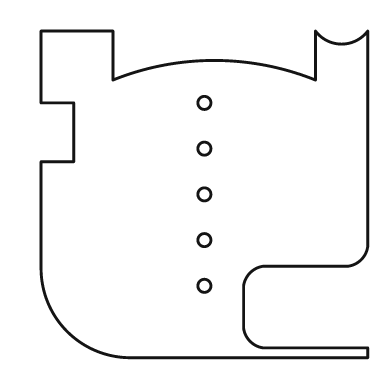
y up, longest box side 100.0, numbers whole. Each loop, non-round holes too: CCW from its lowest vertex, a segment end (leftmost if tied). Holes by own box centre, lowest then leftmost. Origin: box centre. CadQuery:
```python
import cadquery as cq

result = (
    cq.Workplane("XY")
    .moveTo(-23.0, -50.0)
    .lineTo(50.0, -50.0)
    .lineTo(50.0, -47.0)
    .lineTo(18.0, -47.0)
    .threePointArc((14.0, -45.0), (12.0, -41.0))
    .lineTo(12.0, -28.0)
    .threePointArc((14.0, -24.0), (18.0, -22.0))
    .lineTo(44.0, -22.0)
    .threePointArc((48.0, -20.0), (50.0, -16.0))
    .lineTo(50.0, 50.0)
    .threePointArc((42.0, 46.0), (34.0, 50.0))
    .lineTo(34.0, 35.0)
    .threePointArc((3.0, 41.0), (-28.0, 35.0))
    .lineTo(-28.0, 50.0)
    .lineTo(-50.0, 50.0)
    .lineTo(-50.0, 28.0)
    .lineTo(-40.0, 28.0)
    .lineTo(-40.0, 10.0)
    .lineTo(-50.0, 10.0)
    .lineTo(-50.0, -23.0)
    .threePointArc((-42.0, -42.0), (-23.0, -50.0))
    .close()
    .moveTo(0.0, -28.0)
    .circle(2.0)
    .moveTo(0.0, -14.0)
    .circle(2.0)
    .moveTo(0.0, 0.0)
    .circle(2.0)
    .moveTo(0.0, 14.0)
    .circle(2.0)
    .moveTo(0.0, 28.0)
    .circle(2.0)
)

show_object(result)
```